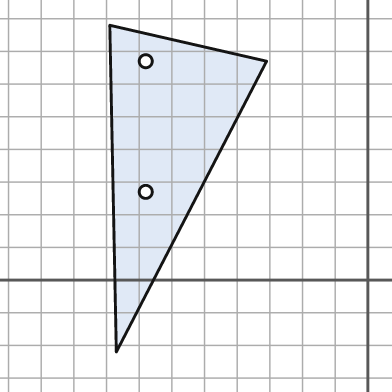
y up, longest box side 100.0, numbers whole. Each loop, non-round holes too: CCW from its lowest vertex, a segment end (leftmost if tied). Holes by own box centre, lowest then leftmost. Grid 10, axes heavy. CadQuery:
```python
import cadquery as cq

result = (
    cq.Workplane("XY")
    .moveTo(-77.0, -22.0)
    .lineTo(-31.0, 67.0)
    .lineTo(-79.0, 78.0)
    .close()
    .moveTo(-68.0, 27.0)
    .circle(2.0)
    .moveTo(-68.0, 67.0)
    .circle(2.0)
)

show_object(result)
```